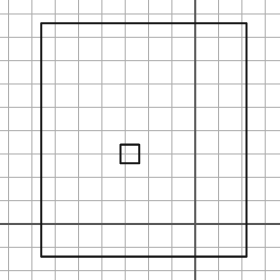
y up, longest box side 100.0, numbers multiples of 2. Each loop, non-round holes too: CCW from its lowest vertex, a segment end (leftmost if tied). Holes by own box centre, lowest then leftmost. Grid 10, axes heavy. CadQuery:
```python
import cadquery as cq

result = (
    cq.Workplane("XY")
    .moveTo(-66.0, -14.0)
    .lineTo(22.0, -14.0)
    .lineTo(22.0, 86.0)
    .lineTo(-66.0, 86.0)
    .close()
    .moveTo(-32.0, 26.0)
    .lineTo(-24.0, 26.0)
    .lineTo(-24.0, 34.0)
    .lineTo(-32.0, 34.0)
    .close()
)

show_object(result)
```